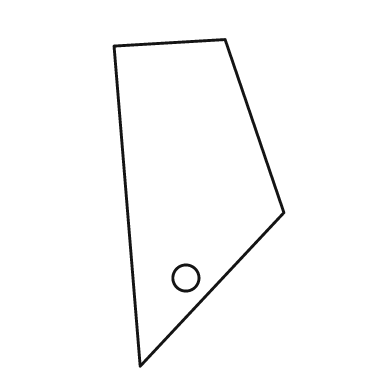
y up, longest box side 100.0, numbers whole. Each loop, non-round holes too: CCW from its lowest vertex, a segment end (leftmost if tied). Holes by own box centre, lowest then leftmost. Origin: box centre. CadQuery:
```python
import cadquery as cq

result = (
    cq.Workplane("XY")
    .moveTo(-18.0, -50.0)
    .lineTo(26.0, -3.0)
    .lineTo(8.0, 50.0)
    .lineTo(-26.0, 48.0)
    .close()
    .moveTo(-4.0, -23.0)
    .circle(4.0)
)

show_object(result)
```